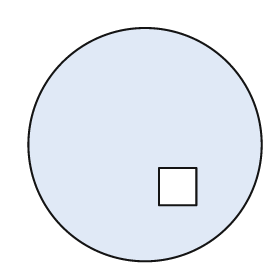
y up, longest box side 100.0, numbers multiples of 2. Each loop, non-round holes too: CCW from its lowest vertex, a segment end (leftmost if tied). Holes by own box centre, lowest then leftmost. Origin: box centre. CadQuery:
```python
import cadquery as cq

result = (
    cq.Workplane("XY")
    .moveTo(0.0, 0.0)
    .circle(50.0)
    .moveTo(6.0, -26.0)
    .lineTo(22.0, -26.0)
    .lineTo(22.0, -10.0)
    .lineTo(6.0, -10.0)
    .close()
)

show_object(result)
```